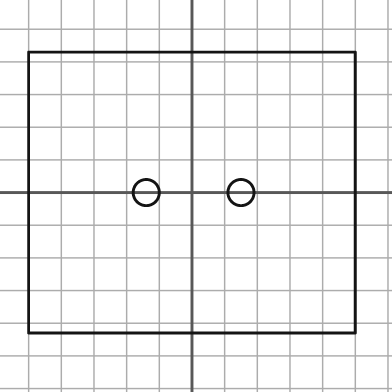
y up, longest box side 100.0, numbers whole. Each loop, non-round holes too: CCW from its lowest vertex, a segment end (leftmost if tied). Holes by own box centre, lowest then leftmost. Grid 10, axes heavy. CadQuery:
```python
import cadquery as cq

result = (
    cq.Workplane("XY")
    .moveTo(-50.0, -43.0)
    .lineTo(50.0, -43.0)
    .lineTo(50.0, 43.0)
    .lineTo(-50.0, 43.0)
    .close()
    .moveTo(-14.0, 0.0)
    .circle(4.0)
    .moveTo(15.0, 0.0)
    .circle(4.0)
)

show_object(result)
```